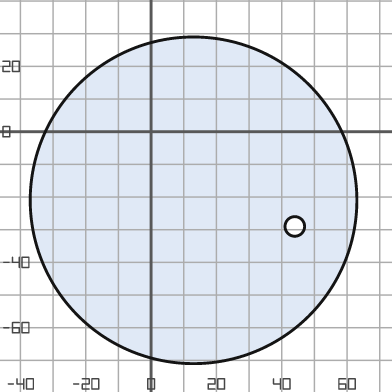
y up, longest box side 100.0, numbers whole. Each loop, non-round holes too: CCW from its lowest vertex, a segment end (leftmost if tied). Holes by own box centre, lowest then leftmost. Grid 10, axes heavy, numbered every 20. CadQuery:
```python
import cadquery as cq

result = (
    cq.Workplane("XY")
    .moveTo(13.0, -21.0)
    .circle(50.0)
    .moveTo(44.0, -29.0)
    .circle(3.0)
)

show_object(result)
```